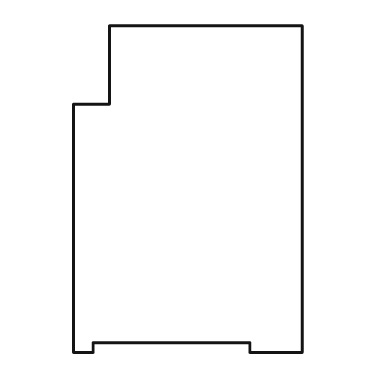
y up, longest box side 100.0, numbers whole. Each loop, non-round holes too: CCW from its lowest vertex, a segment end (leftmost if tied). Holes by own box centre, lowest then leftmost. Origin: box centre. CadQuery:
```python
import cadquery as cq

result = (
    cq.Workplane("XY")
    .moveTo(-35.0, -50.0)
    .lineTo(-29.0, -50.0)
    .lineTo(-29.0, -47.0)
    .lineTo(19.0, -47.0)
    .lineTo(19.0, -50.0)
    .lineTo(35.0, -50.0)
    .lineTo(35.0, 50.0)
    .lineTo(-24.0, 50.0)
    .lineTo(-24.0, 26.0)
    .lineTo(-35.0, 26.0)
    .close()
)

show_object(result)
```